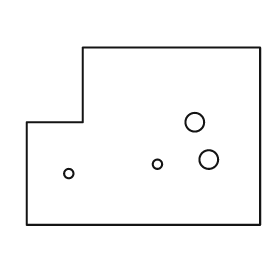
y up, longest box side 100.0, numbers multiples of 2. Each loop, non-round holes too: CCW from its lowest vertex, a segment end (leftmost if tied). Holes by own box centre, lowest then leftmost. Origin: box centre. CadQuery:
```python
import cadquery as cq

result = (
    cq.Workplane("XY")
    .moveTo(-50.0, -38.0)
    .lineTo(50.0, -38.0)
    .lineTo(50.0, 38.0)
    .lineTo(-26.0, 38.0)
    .lineTo(-26.0, 6.0)
    .lineTo(-50.0, 6.0)
    .close()
    .moveTo(-32.0, -16.0)
    .circle(2.0)
    .moveTo(6.0, -12.0)
    .circle(2.0)
    .moveTo(28.0, -10.0)
    .circle(4.0)
    .moveTo(22.0, 6.0)
    .circle(4.0)
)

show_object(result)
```